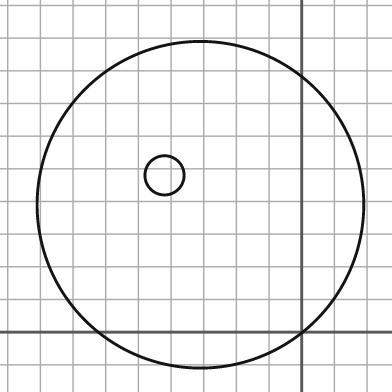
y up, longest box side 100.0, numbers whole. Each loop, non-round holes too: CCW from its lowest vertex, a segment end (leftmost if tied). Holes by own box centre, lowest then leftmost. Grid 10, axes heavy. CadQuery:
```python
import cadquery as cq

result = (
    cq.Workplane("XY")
    .moveTo(-31.0, 39.0)
    .circle(50.0)
    .moveTo(-42.0, 48.0)
    .circle(6.0)
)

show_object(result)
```